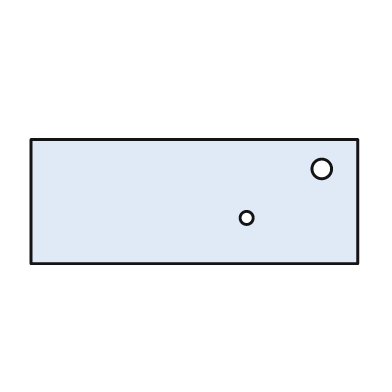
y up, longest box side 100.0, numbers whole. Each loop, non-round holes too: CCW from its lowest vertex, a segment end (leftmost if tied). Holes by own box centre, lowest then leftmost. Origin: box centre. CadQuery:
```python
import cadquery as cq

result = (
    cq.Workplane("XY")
    .moveTo(-50.0, -19.0)
    .lineTo(50.0, -19.0)
    .lineTo(50.0, 19.0)
    .lineTo(-50.0, 19.0)
    .close()
    .moveTo(16.0, -5.0)
    .circle(2.0)
    .moveTo(39.0, 10.0)
    .circle(3.0)
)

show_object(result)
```